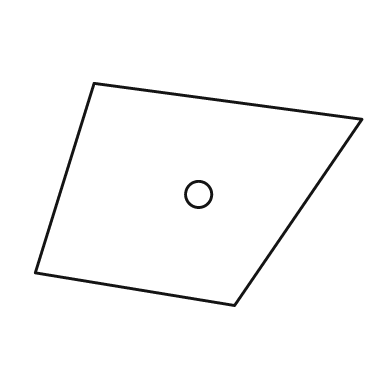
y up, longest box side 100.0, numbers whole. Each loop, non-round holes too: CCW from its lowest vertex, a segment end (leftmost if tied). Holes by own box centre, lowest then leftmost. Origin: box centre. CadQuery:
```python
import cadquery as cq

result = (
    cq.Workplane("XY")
    .moveTo(11.0, -34.0)
    .lineTo(50.0, 23.0)
    .lineTo(-32.0, 34.0)
    .lineTo(-50.0, -24.0)
    .close()
    .moveTo(0.0, 0.0)
    .circle(4.0)
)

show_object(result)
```